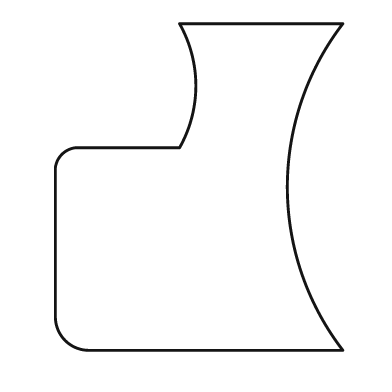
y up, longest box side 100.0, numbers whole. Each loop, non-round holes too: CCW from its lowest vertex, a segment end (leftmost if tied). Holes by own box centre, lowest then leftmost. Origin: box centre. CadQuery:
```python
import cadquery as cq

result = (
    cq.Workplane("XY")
    .moveTo(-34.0, -50.0)
    .lineTo(44.0, -50.0)
    .threePointArc((27.0, 0.0), (44.0, 50.0))
    .lineTo(-6.0, 50.0)
    .threePointArc((-1.0, 31.0), (-6.0, 12.0))
    .lineTo(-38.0, 12.0)
    .threePointArc((-42.0, 10.0), (-44.0, 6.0))
    .lineTo(-44.0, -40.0)
    .threePointArc((-41.0, -47.0), (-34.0, -50.0))
    .close()
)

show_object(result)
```